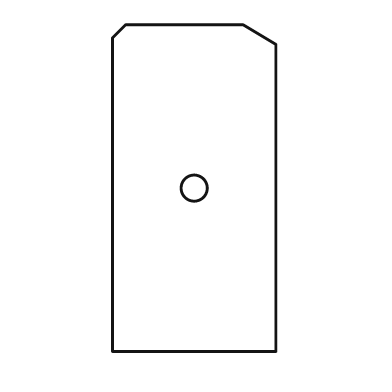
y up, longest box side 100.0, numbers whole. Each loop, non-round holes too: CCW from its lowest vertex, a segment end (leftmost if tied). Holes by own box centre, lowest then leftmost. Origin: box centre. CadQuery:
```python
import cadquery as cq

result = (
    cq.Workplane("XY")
    .moveTo(-25.0, -50.0)
    .lineTo(25.0, -50.0)
    .lineTo(25.0, 44.0)
    .lineTo(15.0, 50.0)
    .lineTo(-21.0, 50.0)
    .lineTo(-25.0, 46.0)
    .close()
    .moveTo(0.0, 0.0)
    .circle(4.0)
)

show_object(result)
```